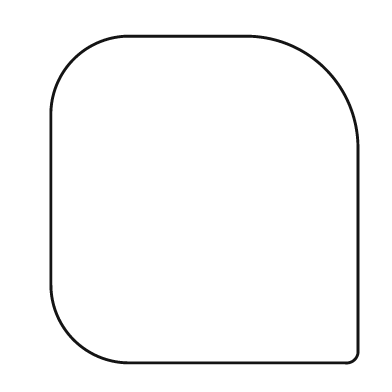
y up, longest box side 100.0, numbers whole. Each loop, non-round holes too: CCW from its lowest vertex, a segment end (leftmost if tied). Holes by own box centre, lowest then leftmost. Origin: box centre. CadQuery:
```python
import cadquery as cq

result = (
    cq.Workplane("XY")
    .moveTo(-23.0, -50.0)
    .lineTo(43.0, -50.0)
    .threePointArc((46.0, -49.0), (47.0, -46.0))
    .lineTo(47.0, 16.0)
    .threePointArc((37.0, 40.0), (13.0, 50.0))
    .lineTo(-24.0, 50.0)
    .threePointArc((-40.0, 43.0), (-47.0, 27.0))
    .lineTo(-47.0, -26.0)
    .threePointArc((-40.0, -43.0), (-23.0, -50.0))
    .close()
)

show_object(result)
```